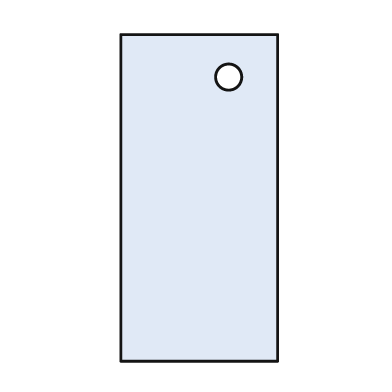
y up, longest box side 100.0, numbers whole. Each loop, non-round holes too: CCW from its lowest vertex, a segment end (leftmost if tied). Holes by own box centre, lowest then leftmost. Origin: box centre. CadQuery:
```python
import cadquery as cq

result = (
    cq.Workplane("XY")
    .moveTo(-24.0, -50.0)
    .lineTo(24.0, -50.0)
    .lineTo(24.0, 50.0)
    .lineTo(-24.0, 50.0)
    .close()
    .moveTo(9.0, 37.0)
    .circle(4.0)
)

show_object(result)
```